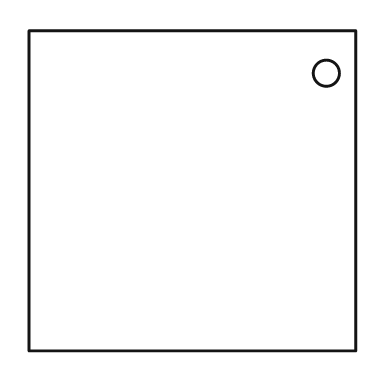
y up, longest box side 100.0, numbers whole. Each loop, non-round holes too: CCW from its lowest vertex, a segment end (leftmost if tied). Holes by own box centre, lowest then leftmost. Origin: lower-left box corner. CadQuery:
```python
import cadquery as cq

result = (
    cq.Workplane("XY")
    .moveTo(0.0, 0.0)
    .lineTo(100.0, 0.0)
    .lineTo(100.0, 98.0)
    .lineTo(0.0, 98.0)
    .close()
    .moveTo(91.0, 85.0)
    .circle(4.0)
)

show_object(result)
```